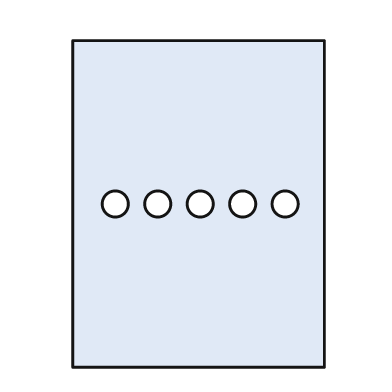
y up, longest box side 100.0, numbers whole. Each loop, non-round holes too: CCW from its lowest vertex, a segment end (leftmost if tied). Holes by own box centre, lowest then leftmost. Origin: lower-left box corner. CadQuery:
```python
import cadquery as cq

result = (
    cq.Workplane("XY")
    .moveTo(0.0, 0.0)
    .lineTo(77.0, 0.0)
    .lineTo(77.0, 100.0)
    .lineTo(0.0, 100.0)
    .close()
    .moveTo(13.0, 50.0)
    .circle(4.0)
    .moveTo(26.0, 50.0)
    .circle(4.0)
    .moveTo(39.0, 50.0)
    .circle(4.0)
    .moveTo(52.0, 50.0)
    .circle(4.0)
    .moveTo(65.0, 50.0)
    .circle(4.0)
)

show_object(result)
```